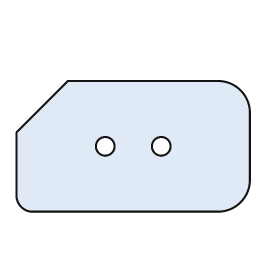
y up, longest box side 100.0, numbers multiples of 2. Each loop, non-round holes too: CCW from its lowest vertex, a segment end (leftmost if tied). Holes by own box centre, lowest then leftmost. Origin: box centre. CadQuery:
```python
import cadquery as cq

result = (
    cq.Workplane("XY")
    .moveTo(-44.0, -28.0)
    .lineTo(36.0, -28.0)
    .threePointArc((46.0, -24.0), (50.0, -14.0))
    .lineTo(50.0, 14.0)
    .threePointArc((46.0, 24.0), (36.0, 28.0))
    .lineTo(-28.0, 28.0)
    .lineTo(-50.0, 6.0)
    .lineTo(-50.0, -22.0)
    .threePointArc((-48.0, -26.0), (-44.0, -28.0))
    .close()
    .moveTo(-12.0, 0.0)
    .circle(4.0)
    .moveTo(12.0, 0.0)
    .circle(4.0)
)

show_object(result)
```